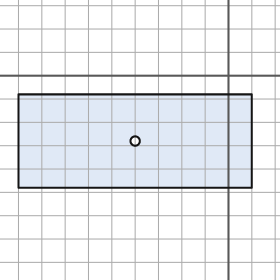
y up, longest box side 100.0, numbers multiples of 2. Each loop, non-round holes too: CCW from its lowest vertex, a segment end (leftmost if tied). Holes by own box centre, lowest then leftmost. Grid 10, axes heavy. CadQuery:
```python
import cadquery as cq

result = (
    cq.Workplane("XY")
    .moveTo(-90.0, -48.0)
    .lineTo(10.0, -48.0)
    .lineTo(10.0, -8.0)
    .lineTo(-90.0, -8.0)
    .close()
    .moveTo(-40.0, -28.0)
    .circle(2.0)
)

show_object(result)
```